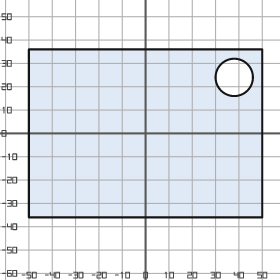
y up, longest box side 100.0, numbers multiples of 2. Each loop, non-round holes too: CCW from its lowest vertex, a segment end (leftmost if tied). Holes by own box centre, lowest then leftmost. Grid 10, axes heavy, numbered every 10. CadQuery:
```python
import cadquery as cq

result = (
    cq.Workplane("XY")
    .moveTo(-50.0, -36.0)
    .lineTo(50.0, -36.0)
    .lineTo(50.0, 36.0)
    .lineTo(-50.0, 36.0)
    .close()
    .moveTo(38.0, 24.0)
    .circle(8.0)
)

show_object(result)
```